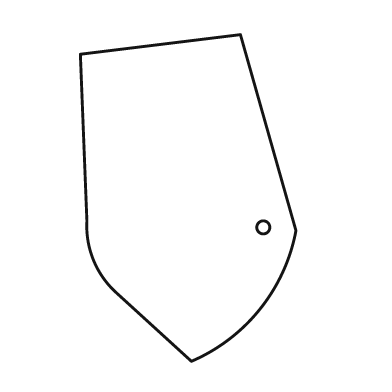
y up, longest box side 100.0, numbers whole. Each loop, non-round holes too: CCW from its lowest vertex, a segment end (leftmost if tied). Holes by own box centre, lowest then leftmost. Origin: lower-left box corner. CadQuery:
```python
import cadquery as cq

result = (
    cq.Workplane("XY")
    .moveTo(34.0, 0.0)
    .threePointArc((55.0, 16.0), (66.0, 40.0))
    .lineTo(49.0, 100.0)
    .lineTo(0.0, 94.0)
    .lineTo(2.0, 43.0)
    .threePointArc((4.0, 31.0), (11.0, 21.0))
    .close()
    .moveTo(56.0, 41.0)
    .circle(2.0)
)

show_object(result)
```